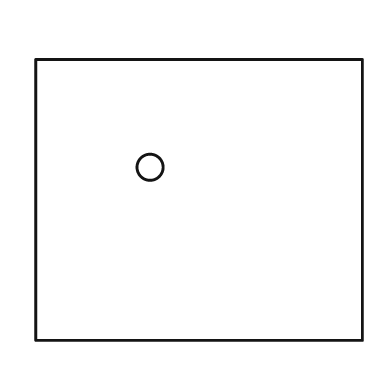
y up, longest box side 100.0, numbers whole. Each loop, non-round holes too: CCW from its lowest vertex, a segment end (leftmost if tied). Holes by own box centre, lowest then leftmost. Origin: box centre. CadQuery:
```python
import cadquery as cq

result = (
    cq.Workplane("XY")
    .moveTo(-50.0, -43.0)
    .lineTo(50.0, -43.0)
    .lineTo(50.0, 43.0)
    .lineTo(-50.0, 43.0)
    .close()
    .moveTo(-15.0, 10.0)
    .circle(4.0)
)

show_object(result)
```